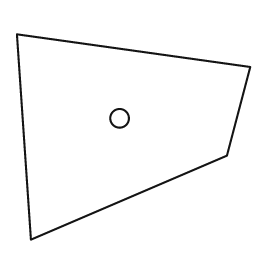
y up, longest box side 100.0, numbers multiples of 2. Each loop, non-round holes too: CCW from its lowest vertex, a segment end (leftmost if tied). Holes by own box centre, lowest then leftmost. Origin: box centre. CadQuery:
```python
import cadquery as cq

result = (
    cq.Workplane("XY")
    .moveTo(-44.0, -44.0)
    .lineTo(40.0, -8.0)
    .lineTo(50.0, 30.0)
    .lineTo(-50.0, 44.0)
    .close()
    .moveTo(-6.0, 8.0)
    .circle(4.0)
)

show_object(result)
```